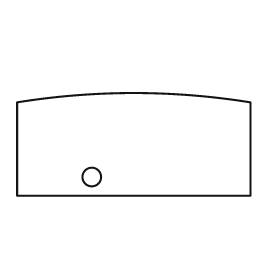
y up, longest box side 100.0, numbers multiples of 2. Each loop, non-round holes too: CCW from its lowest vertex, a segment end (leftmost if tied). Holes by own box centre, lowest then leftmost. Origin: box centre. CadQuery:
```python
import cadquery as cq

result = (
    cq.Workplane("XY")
    .moveTo(-50.0, -22.0)
    .lineTo(50.0, -22.0)
    .lineTo(50.0, 18.0)
    .threePointArc((0.0, 22.0), (-50.0, 18.0))
    .close()
    .moveTo(-18.0, -14.0)
    .circle(4.0)
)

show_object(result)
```